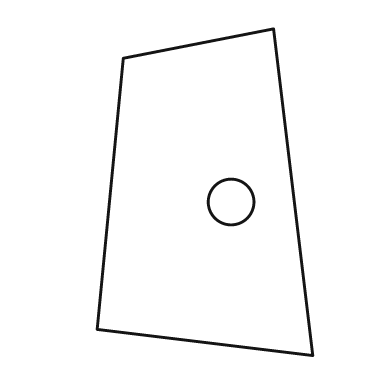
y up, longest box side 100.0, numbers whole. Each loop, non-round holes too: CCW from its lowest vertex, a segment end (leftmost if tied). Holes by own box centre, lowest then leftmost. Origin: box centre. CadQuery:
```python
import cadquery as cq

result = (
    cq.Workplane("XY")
    .moveTo(33.0, -50.0)
    .lineTo(21.0, 50.0)
    .lineTo(-25.0, 41.0)
    .lineTo(-33.0, -42.0)
    .close()
    .moveTo(8.0, -3.0)
    .circle(7.0)
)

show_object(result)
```